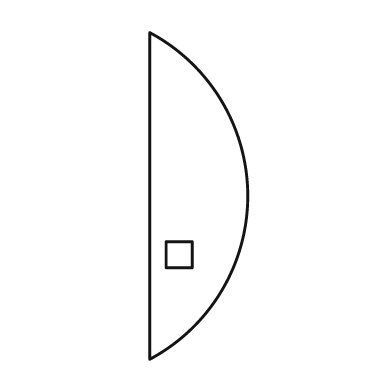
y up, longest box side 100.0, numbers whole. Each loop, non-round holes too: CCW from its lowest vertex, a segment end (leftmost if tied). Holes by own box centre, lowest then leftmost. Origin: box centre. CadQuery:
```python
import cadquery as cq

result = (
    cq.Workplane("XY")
    .moveTo(-15.0, -50.0)
    .threePointArc((15.0, 0.0), (-15.0, 50.0))
    .close()
    .moveTo(-10.0, -22.0)
    .lineTo(-2.0, -22.0)
    .lineTo(-2.0, -14.0)
    .lineTo(-10.0, -14.0)
    .close()
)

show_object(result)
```